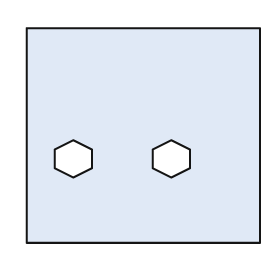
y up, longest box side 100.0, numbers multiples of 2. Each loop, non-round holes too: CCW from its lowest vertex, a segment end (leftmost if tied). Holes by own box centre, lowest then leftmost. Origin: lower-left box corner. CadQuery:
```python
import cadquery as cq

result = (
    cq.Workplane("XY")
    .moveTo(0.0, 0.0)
    .lineTo(100.0, 0.0)
    .lineTo(100.0, 92.0)
    .lineTo(0.0, 92.0)
    .close()
    .moveTo(20.0, 28.0)
    .lineTo(28.0, 32.0)
    .lineTo(28.0, 40.0)
    .lineTo(20.0, 44.0)
    .lineTo(12.0, 40.0)
    .lineTo(12.0, 32.0)
    .close()
    .moveTo(62.0, 28.0)
    .lineTo(70.0, 32.0)
    .lineTo(70.0, 40.0)
    .lineTo(62.0, 44.0)
    .lineTo(54.0, 40.0)
    .lineTo(54.0, 32.0)
    .close()
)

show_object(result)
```